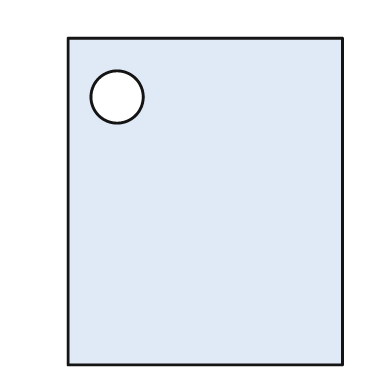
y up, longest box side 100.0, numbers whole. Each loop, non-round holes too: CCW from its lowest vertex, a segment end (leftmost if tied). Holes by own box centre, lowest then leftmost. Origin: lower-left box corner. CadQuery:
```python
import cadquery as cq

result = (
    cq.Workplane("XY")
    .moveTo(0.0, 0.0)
    .lineTo(84.0, 0.0)
    .lineTo(84.0, 100.0)
    .lineTo(0.0, 100.0)
    .close()
    .moveTo(15.0, 82.0)
    .circle(8.0)
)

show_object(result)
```